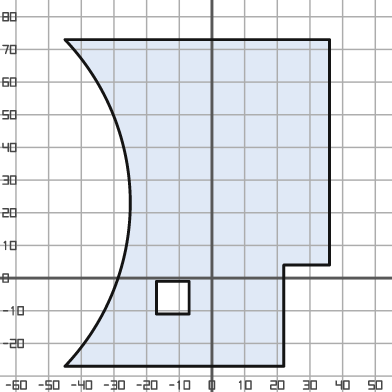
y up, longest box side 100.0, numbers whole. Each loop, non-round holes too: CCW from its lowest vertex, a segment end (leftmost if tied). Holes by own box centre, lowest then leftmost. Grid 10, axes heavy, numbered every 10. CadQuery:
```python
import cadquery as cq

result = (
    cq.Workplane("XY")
    .moveTo(-45.0, -27.0)
    .lineTo(22.0, -27.0)
    .lineTo(22.0, 4.0)
    .lineTo(36.0, 4.0)
    .lineTo(36.0, 73.0)
    .lineTo(-45.0, 73.0)
    .threePointArc((-25.0, 23.0), (-45.0, -27.0))
    .close()
    .moveTo(-17.0, -11.0)
    .lineTo(-7.0, -11.0)
    .lineTo(-7.0, -1.0)
    .lineTo(-17.0, -1.0)
    .close()
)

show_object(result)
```